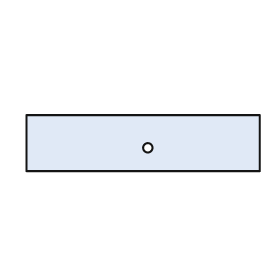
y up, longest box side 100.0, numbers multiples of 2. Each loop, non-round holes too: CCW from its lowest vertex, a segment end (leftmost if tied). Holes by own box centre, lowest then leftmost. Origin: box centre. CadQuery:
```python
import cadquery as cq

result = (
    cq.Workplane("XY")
    .moveTo(-50.0, -12.0)
    .lineTo(50.0, -12.0)
    .lineTo(50.0, 12.0)
    .lineTo(-50.0, 12.0)
    .close()
    .moveTo(2.0, -2.0)
    .circle(2.0)
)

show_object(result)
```